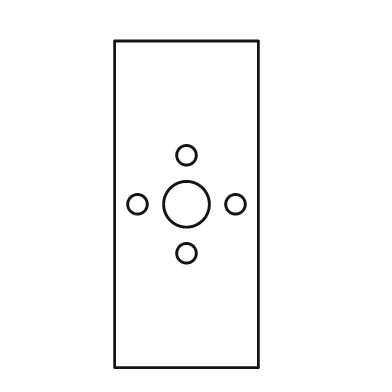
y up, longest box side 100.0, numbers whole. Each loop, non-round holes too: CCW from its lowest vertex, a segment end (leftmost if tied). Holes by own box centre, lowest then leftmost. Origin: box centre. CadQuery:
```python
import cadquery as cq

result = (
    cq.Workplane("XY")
    .moveTo(-22.0, -50.0)
    .lineTo(22.0, -50.0)
    .lineTo(22.0, 50.0)
    .lineTo(-22.0, 50.0)
    .close()
    .moveTo(0.0, -15.0)
    .circle(3.0)
    .moveTo(-15.0, 0.0)
    .circle(3.0)
    .moveTo(0.0, 0.0)
    .circle(7.0)
    .moveTo(15.0, 0.0)
    .circle(3.0)
    .moveTo(0.0, 15.0)
    .circle(3.0)
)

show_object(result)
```